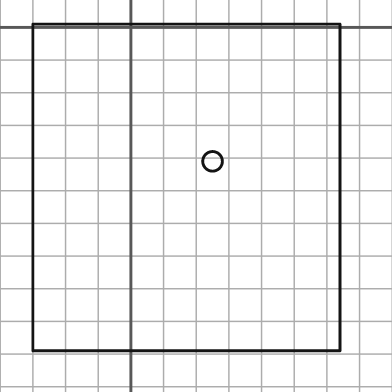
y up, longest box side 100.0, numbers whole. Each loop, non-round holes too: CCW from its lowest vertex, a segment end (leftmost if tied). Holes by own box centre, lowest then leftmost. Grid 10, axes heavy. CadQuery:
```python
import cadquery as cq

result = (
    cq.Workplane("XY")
    .moveTo(-30.0, -99.0)
    .lineTo(64.0, -99.0)
    .lineTo(64.0, 1.0)
    .lineTo(-30.0, 1.0)
    .close()
    .moveTo(25.0, -41.0)
    .circle(3.0)
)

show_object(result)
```